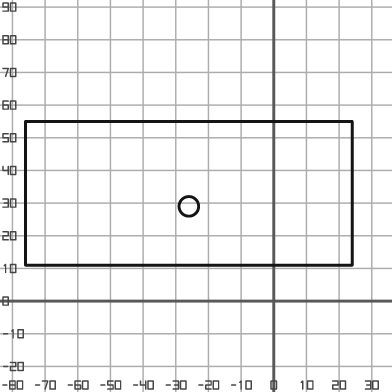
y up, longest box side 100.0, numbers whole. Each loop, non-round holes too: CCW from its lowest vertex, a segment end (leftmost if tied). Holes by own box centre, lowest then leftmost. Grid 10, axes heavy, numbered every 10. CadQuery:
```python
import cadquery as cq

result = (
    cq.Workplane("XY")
    .moveTo(-76.0, 11.0)
    .lineTo(24.0, 11.0)
    .lineTo(24.0, 55.0)
    .lineTo(-76.0, 55.0)
    .close()
    .moveTo(-26.0, 29.0)
    .circle(3.0)
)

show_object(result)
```